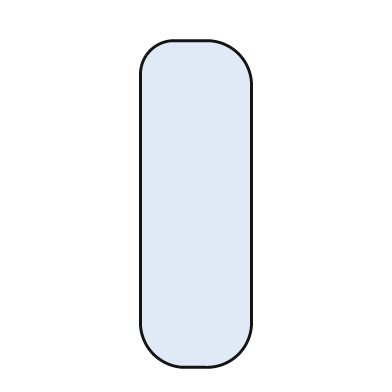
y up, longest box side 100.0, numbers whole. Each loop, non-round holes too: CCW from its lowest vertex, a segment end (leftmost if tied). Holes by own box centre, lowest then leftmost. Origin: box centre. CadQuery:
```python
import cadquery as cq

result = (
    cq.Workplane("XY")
    .moveTo(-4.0, -50.0)
    .lineTo(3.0, -50.0)
    .threePointArc((13.0, -46.0), (17.0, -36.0))
    .lineTo(17.0, 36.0)
    .threePointArc((13.0, 46.0), (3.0, 50.0))
    .lineTo(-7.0, 50.0)
    .threePointArc((-14.0, 47.0), (-17.0, 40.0))
    .lineTo(-17.0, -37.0)
    .threePointArc((-13.0, -46.0), (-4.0, -50.0))
    .close()
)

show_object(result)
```